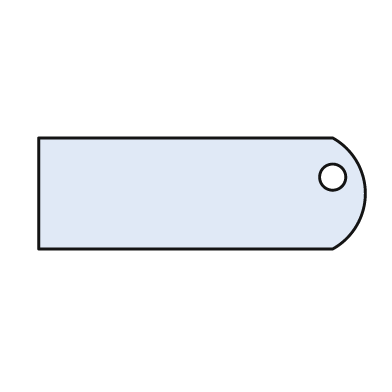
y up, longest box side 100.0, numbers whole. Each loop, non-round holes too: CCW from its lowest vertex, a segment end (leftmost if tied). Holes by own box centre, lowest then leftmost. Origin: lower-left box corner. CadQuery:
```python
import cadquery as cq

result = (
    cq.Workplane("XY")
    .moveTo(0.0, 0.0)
    .lineTo(90.0, 0.0)
    .threePointArc((100.0, 17.0), (90.0, 34.0))
    .lineTo(0.0, 34.0)
    .close()
    .moveTo(90.0, 22.0)
    .circle(4.0)
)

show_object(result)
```